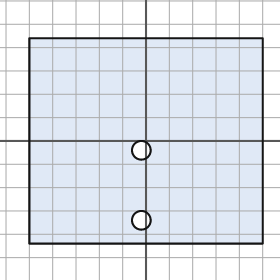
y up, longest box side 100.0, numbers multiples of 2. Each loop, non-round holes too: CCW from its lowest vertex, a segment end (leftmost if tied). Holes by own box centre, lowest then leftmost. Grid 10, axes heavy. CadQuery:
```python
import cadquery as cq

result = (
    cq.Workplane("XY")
    .moveTo(-50.0, -44.0)
    .lineTo(50.0, -44.0)
    .lineTo(50.0, 44.0)
    .lineTo(-50.0, 44.0)
    .close()
    .moveTo(-2.0, -34.0)
    .circle(4.0)
    .moveTo(-2.0, -4.0)
    .circle(4.0)
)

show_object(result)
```